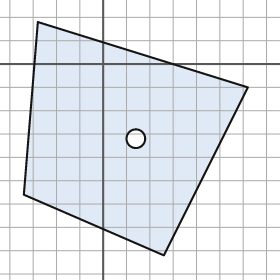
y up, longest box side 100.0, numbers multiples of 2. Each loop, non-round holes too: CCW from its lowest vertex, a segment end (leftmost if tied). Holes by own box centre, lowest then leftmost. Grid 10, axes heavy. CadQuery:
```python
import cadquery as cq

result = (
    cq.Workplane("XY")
    .moveTo(26.0, -82.0)
    .lineTo(62.0, -10.0)
    .lineTo(-28.0, 18.0)
    .lineTo(-34.0, -56.0)
    .close()
    .moveTo(14.0, -32.0)
    .circle(4.0)
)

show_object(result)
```